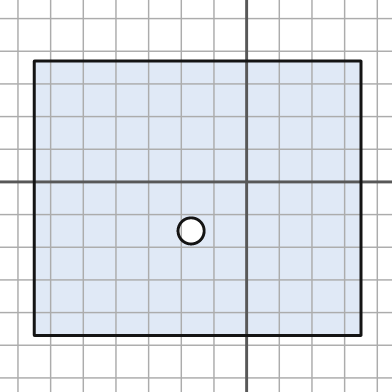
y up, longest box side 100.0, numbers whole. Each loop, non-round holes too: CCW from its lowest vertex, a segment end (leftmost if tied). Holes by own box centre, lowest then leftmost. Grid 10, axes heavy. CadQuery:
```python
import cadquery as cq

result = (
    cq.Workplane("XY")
    .moveTo(-65.0, -47.0)
    .lineTo(35.0, -47.0)
    .lineTo(35.0, 37.0)
    .lineTo(-65.0, 37.0)
    .close()
    .moveTo(-17.0, -15.0)
    .circle(4.0)
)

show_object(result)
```